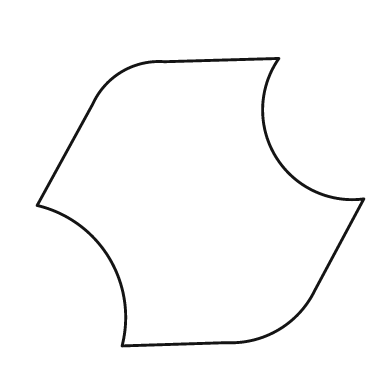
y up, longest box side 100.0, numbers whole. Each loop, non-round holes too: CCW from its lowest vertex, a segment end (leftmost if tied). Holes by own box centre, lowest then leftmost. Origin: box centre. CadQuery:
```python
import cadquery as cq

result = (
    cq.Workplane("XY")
    .moveTo(-24.0, -44.0)
    .lineTo(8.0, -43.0)
    .threePointArc((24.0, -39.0), (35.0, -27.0))
    .lineTo(50.0, 1.0)
    .threePointArc((23.0, 14.0), (24.0, 44.0))
    .lineTo(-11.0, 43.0)
    .threePointArc((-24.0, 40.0), (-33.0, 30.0))
    .lineTo(-50.0, -1.0)
    .threePointArc((-28.0, -17.0), (-24.0, -44.0))
    .close()
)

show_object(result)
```